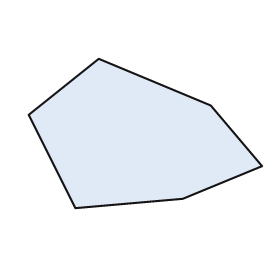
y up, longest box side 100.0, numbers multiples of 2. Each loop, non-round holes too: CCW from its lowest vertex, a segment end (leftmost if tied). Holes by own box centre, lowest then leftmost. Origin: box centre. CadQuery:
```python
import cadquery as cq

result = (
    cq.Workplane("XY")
    .moveTo(-30.0, -32.0)
    .lineTo(16.0, -28.0)
    .lineTo(50.0, -14.0)
    .lineTo(28.0, 12.0)
    .lineTo(-20.0, 32.0)
    .lineTo(-50.0, 8.0)
    .close()
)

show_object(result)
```